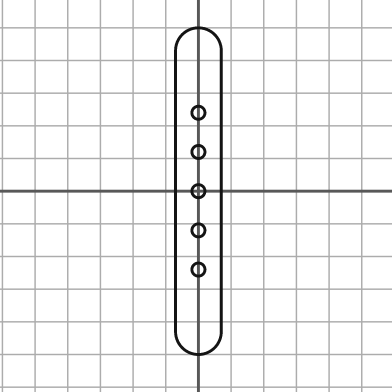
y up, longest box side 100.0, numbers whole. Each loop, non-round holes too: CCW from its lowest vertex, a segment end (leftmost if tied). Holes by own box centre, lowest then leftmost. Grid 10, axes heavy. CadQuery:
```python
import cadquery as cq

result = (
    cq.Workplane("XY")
    .moveTo(-7.0, -43.0)
    .threePointArc((0.0, -50.0), (7.0, -43.0))
    .lineTo(7.0, 43.0)
    .threePointArc((0.0, 50.0), (-7.0, 43.0))
    .close()
    .moveTo(0.0, -24.0)
    .circle(2.0)
    .moveTo(0.0, -12.0)
    .circle(2.0)
    .moveTo(0.0, 0.0)
    .circle(2.0)
    .moveTo(0.0, 12.0)
    .circle(2.0)
    .moveTo(0.0, 24.0)
    .circle(2.0)
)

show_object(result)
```